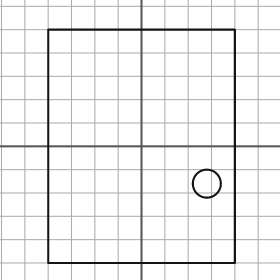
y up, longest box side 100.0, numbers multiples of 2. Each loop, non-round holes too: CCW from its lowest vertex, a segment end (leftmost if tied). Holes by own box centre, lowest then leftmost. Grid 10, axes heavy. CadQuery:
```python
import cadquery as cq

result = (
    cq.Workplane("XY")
    .moveTo(-40.0, -50.0)
    .lineTo(40.0, -50.0)
    .lineTo(40.0, 50.0)
    .lineTo(-40.0, 50.0)
    .close()
    .moveTo(28.0, -16.0)
    .circle(6.0)
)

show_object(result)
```